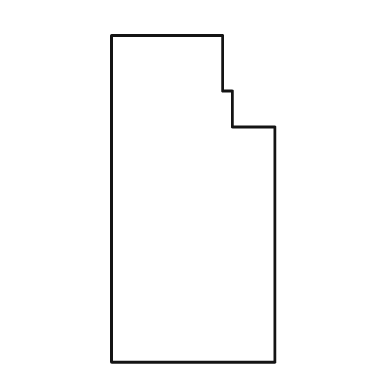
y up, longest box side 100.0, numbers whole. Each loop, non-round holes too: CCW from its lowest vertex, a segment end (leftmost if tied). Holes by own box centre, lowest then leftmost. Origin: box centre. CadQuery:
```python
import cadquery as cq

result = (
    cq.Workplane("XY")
    .moveTo(-25.0, -50.0)
    .lineTo(25.0, -50.0)
    .lineTo(25.0, 22.0)
    .lineTo(12.0, 22.0)
    .lineTo(12.0, 33.0)
    .lineTo(9.0, 33.0)
    .lineTo(9.0, 50.0)
    .lineTo(-25.0, 50.0)
    .close()
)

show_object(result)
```